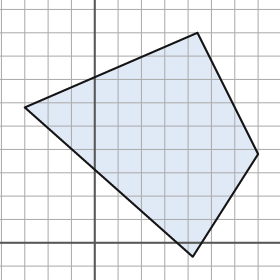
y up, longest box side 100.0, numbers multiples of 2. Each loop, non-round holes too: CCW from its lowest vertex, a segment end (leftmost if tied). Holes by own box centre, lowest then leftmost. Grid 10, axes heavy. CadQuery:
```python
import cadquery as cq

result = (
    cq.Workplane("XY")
    .moveTo(42.0, -6.0)
    .lineTo(70.0, 38.0)
    .lineTo(44.0, 90.0)
    .lineTo(-30.0, 58.0)
    .close()
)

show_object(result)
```